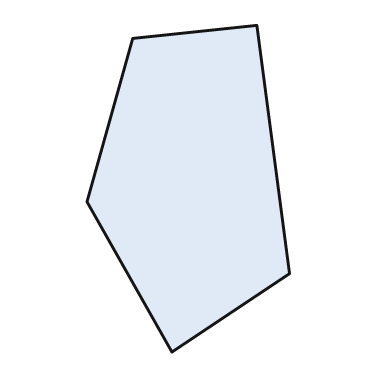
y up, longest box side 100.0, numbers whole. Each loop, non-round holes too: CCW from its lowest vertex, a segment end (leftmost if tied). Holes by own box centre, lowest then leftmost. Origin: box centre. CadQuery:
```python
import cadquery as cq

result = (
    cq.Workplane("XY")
    .moveTo(-5.0, -50.0)
    .lineTo(31.0, -26.0)
    .lineTo(21.0, 50.0)
    .lineTo(-17.0, 46.0)
    .lineTo(-31.0, -4.0)
    .close()
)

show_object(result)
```